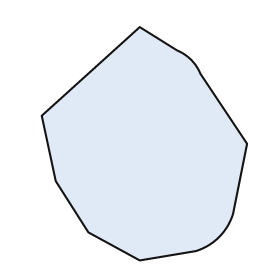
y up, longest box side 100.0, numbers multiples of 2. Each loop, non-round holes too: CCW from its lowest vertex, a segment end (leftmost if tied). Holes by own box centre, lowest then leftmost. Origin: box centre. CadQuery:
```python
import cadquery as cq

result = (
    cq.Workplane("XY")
    .moveTo(-2.0, -50.0)
    .lineTo(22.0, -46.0)
    .threePointArc((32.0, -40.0), (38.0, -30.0))
    .lineTo(44.0, 0.0)
    .lineTo(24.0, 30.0)
    .threePointArc((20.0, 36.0), (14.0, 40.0))
    .lineTo(-2.0, 50.0)
    .lineTo(-44.0, 12.0)
    .lineTo(-38.0, -16.0)
    .lineTo(-24.0, -38.0)
    .close()
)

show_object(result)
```